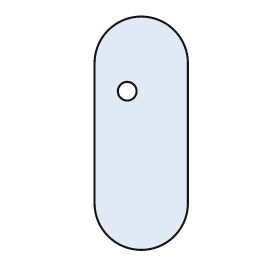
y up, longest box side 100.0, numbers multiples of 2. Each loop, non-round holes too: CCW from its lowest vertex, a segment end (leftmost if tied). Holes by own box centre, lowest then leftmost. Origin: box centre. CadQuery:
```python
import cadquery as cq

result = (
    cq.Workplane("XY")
    .moveTo(-20.0, -30.0)
    .threePointArc((0.0, -50.0), (20.0, -30.0))
    .lineTo(20.0, 30.0)
    .threePointArc((0.0, 50.0), (-20.0, 30.0))
    .close()
    .moveTo(-6.0, 18.0)
    .circle(4.0)
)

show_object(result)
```